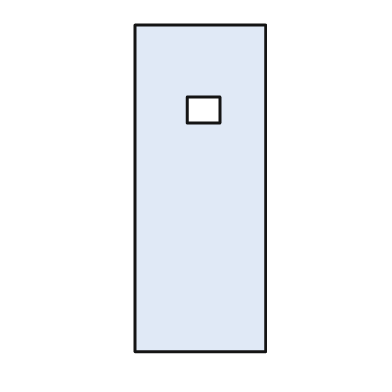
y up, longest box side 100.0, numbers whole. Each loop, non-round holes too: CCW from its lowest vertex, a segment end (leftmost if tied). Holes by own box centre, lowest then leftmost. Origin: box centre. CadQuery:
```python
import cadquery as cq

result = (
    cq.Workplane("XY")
    .moveTo(-20.0, -50.0)
    .lineTo(20.0, -50.0)
    .lineTo(20.0, 50.0)
    .lineTo(-20.0, 50.0)
    .close()
    .moveTo(-4.0, 20.0)
    .lineTo(6.0, 20.0)
    .lineTo(6.0, 28.0)
    .lineTo(-4.0, 28.0)
    .close()
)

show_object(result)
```